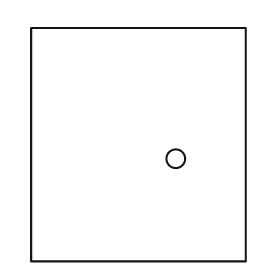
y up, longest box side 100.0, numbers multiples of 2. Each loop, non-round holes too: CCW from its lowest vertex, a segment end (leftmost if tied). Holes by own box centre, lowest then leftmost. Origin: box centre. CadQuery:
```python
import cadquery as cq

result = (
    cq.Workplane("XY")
    .moveTo(-46.0, -50.0)
    .lineTo(46.0, -50.0)
    .lineTo(46.0, 50.0)
    .lineTo(-46.0, 50.0)
    .close()
    .moveTo(16.0, -6.0)
    .circle(4.0)
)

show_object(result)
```